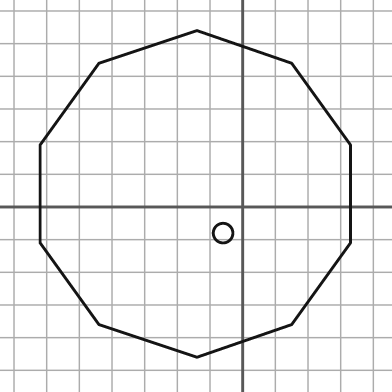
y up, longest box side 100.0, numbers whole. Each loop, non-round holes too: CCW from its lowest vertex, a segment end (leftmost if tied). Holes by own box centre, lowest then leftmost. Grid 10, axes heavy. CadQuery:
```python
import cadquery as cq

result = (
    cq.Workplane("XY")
    .moveTo(-14.0, -46.0)
    .lineTo(15.0, -36.0)
    .lineTo(33.0, -11.0)
    .lineTo(33.0, 19.0)
    .lineTo(15.0, 44.0)
    .lineTo(-14.0, 54.0)
    .lineTo(-44.0, 44.0)
    .lineTo(-62.0, 19.0)
    .lineTo(-62.0, -11.0)
    .lineTo(-44.0, -36.0)
    .close()
    .moveTo(-6.0, -8.0)
    .circle(3.0)
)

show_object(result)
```